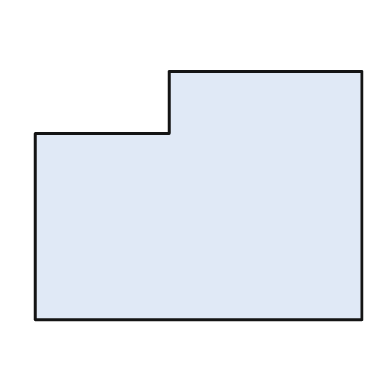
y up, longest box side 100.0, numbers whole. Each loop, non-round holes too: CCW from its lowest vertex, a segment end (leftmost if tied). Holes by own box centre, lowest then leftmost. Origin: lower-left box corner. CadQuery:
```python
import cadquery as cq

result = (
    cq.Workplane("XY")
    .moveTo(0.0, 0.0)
    .lineTo(100.0, 0.0)
    .lineTo(100.0, 76.0)
    .lineTo(41.0, 76.0)
    .lineTo(41.0, 57.0)
    .lineTo(0.0, 57.0)
    .close()
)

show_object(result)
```